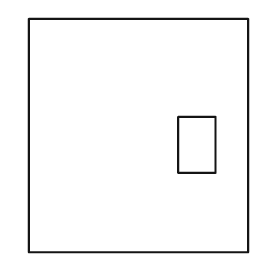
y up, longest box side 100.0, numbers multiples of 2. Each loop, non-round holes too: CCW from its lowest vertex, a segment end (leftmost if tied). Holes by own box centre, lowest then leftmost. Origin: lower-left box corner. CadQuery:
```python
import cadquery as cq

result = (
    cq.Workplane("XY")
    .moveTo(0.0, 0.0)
    .lineTo(94.0, 0.0)
    .lineTo(94.0, 100.0)
    .lineTo(0.0, 100.0)
    .close()
    .moveTo(64.0, 34.0)
    .lineTo(80.0, 34.0)
    .lineTo(80.0, 58.0)
    .lineTo(64.0, 58.0)
    .close()
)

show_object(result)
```